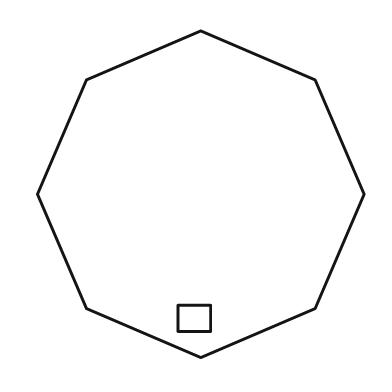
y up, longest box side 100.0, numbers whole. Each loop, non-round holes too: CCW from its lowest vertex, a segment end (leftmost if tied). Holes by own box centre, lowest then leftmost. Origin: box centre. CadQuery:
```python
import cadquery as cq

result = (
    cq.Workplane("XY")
    .moveTo(0.0, -50.0)
    .lineTo(35.0, -35.0)
    .lineTo(50.0, 0.0)
    .lineTo(35.0, 35.0)
    .lineTo(0.0, 50.0)
    .lineTo(-35.0, 35.0)
    .lineTo(-50.0, 0.0)
    .lineTo(-35.0, -35.0)
    .close()
    .moveTo(-7.0, -42.0)
    .lineTo(3.0, -42.0)
    .lineTo(3.0, -34.0)
    .lineTo(-7.0, -34.0)
    .close()
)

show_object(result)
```